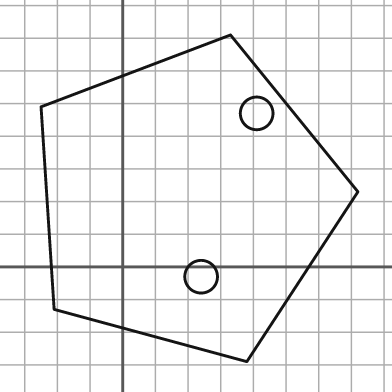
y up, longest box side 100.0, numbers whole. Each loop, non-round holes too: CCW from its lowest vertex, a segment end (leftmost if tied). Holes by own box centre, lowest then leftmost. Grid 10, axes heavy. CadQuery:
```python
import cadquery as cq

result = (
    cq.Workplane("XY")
    .moveTo(38.0, -29.0)
    .lineTo(72.0, 23.0)
    .lineTo(33.0, 71.0)
    .lineTo(-25.0, 49.0)
    .lineTo(-21.0, -13.0)
    .close()
    .moveTo(24.0, -3.0)
    .circle(5.0)
    .moveTo(41.0, 47.0)
    .circle(5.0)
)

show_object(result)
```